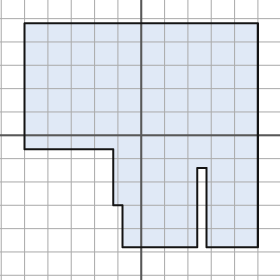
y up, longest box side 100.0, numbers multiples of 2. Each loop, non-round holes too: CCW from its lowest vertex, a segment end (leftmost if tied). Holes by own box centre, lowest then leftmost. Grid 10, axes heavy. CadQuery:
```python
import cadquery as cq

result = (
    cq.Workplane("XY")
    .moveTo(-8.0, -48.0)
    .lineTo(24.0, -48.0)
    .lineTo(24.0, -14.0)
    .lineTo(28.0, -14.0)
    .lineTo(28.0, -48.0)
    .lineTo(50.0, -48.0)
    .lineTo(50.0, 48.0)
    .lineTo(-50.0, 48.0)
    .lineTo(-50.0, -6.0)
    .lineTo(-12.0, -6.0)
    .lineTo(-12.0, -30.0)
    .lineTo(-8.0, -30.0)
    .close()
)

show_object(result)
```